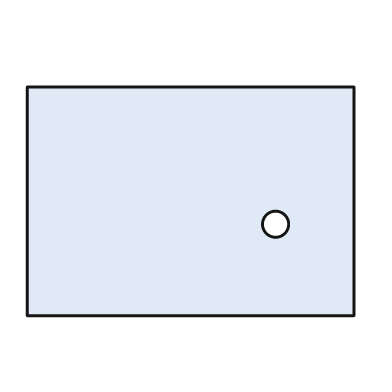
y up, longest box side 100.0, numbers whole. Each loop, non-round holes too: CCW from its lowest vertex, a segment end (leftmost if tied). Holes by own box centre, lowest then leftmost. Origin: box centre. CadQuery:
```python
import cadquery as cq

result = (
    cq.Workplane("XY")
    .moveTo(-50.0, -35.0)
    .lineTo(50.0, -35.0)
    .lineTo(50.0, 35.0)
    .lineTo(-50.0, 35.0)
    .close()
    .moveTo(26.0, -7.0)
    .circle(4.0)
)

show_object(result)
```